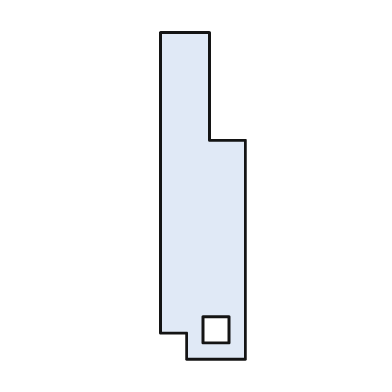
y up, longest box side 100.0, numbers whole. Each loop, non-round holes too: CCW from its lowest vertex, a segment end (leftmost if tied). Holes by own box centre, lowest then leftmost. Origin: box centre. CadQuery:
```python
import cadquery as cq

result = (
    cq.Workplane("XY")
    .moveTo(-5.0, -50.0)
    .lineTo(13.0, -50.0)
    .lineTo(13.0, 17.0)
    .lineTo(2.0, 17.0)
    .lineTo(2.0, 50.0)
    .lineTo(-13.0, 50.0)
    .lineTo(-13.0, -42.0)
    .lineTo(-5.0, -42.0)
    .close()
    .moveTo(0.0, -45.0)
    .lineTo(8.0, -45.0)
    .lineTo(8.0, -37.0)
    .lineTo(0.0, -37.0)
    .close()
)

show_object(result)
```